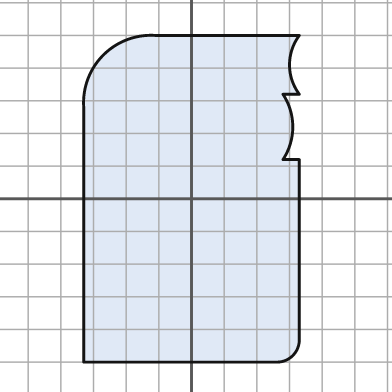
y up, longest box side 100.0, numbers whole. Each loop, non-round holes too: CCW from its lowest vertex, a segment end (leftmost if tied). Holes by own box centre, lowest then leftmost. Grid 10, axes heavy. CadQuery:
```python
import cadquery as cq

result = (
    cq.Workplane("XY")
    .moveTo(-33.0, -50.0)
    .lineTo(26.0, -50.0)
    .threePointArc((31.0, -48.0), (33.0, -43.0))
    .lineTo(33.0, 12.0)
    .lineTo(28.0, 12.0)
    .threePointArc((31.0, 22.0), (28.0, 32.0))
    .lineTo(33.0, 32.0)
    .threePointArc((30.0, 41.0), (33.0, 50.0))
    .lineTo(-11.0, 50.0)
    .threePointArc((-27.0, 44.0), (-33.0, 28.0))
    .close()
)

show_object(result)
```